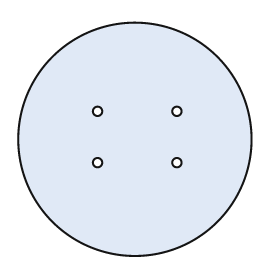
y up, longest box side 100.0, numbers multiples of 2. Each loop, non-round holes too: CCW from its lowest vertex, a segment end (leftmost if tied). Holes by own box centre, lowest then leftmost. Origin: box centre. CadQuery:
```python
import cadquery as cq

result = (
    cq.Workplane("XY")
    .moveTo(0.0, 0.0)
    .circle(50.0)
    .moveTo(-16.0, -10.0)
    .circle(2.0)
    .moveTo(18.0, -10.0)
    .circle(2.0)
    .moveTo(-16.0, 12.0)
    .circle(2.0)
    .moveTo(18.0, 12.0)
    .circle(2.0)
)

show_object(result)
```